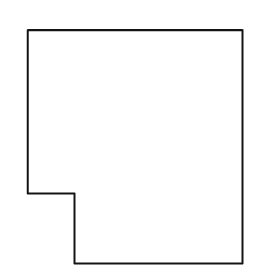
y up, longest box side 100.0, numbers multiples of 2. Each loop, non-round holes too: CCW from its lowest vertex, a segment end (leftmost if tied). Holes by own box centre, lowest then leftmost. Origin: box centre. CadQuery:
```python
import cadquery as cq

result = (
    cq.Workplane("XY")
    .moveTo(-26.0, -50.0)
    .lineTo(46.0, -50.0)
    .lineTo(46.0, 50.0)
    .lineTo(-46.0, 50.0)
    .lineTo(-46.0, -20.0)
    .lineTo(-26.0, -20.0)
    .close()
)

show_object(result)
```